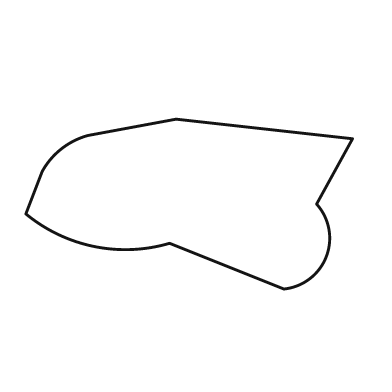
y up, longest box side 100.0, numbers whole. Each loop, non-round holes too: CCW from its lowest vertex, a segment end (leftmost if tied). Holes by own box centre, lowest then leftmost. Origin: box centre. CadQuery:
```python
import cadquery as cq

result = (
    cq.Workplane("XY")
    .moveTo(29.0, -26.0)
    .threePointArc((42.0, -16.0), (39.0, 0.0))
    .lineTo(50.0, 20.0)
    .lineTo(-4.0, 26.0)
    .lineTo(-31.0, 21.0)
    .threePointArc((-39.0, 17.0), (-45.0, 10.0))
    .lineTo(-50.0, -3.0)
    .threePointArc((-29.0, -13.0), (-6.0, -12.0))
    .close()
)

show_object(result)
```